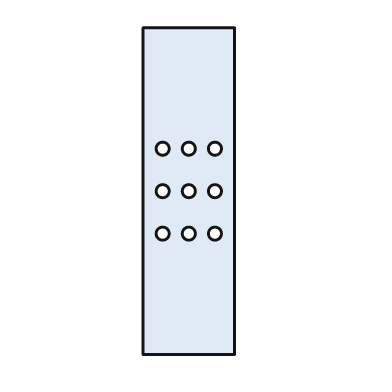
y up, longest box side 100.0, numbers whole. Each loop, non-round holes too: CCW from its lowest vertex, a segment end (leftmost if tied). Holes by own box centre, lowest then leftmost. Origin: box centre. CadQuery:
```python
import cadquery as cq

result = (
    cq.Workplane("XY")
    .moveTo(-14.0, -50.0)
    .lineTo(14.0, -50.0)
    .lineTo(14.0, 50.0)
    .lineTo(-14.0, 50.0)
    .close()
    .moveTo(-8.0, -13.0)
    .circle(2.0)
    .moveTo(0.0, -13.0)
    .circle(2.0)
    .moveTo(8.0, -13.0)
    .circle(2.0)
    .moveTo(-8.0, 0.0)
    .circle(2.0)
    .moveTo(0.0, 0.0)
    .circle(2.0)
    .moveTo(8.0, 0.0)
    .circle(2.0)
    .moveTo(-8.0, 13.0)
    .circle(2.0)
    .moveTo(0.0, 13.0)
    .circle(2.0)
    .moveTo(8.0, 13.0)
    .circle(2.0)
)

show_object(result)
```